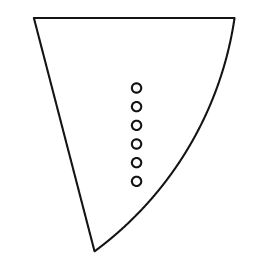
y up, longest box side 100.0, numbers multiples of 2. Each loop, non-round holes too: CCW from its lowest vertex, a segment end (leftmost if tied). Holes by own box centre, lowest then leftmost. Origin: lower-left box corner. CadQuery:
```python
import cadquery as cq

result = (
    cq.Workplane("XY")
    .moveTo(26.0, 0.0)
    .threePointArc((66.0, 44.0), (86.0, 100.0))
    .lineTo(0.0, 100.0)
    .close()
    .moveTo(44.0, 30.0)
    .circle(2.0)
    .moveTo(44.0, 38.0)
    .circle(2.0)
    .moveTo(44.0, 46.0)
    .circle(2.0)
    .moveTo(44.0, 54.0)
    .circle(2.0)
    .moveTo(44.0, 62.0)
    .circle(2.0)
    .moveTo(44.0, 70.0)
    .circle(2.0)
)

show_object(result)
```